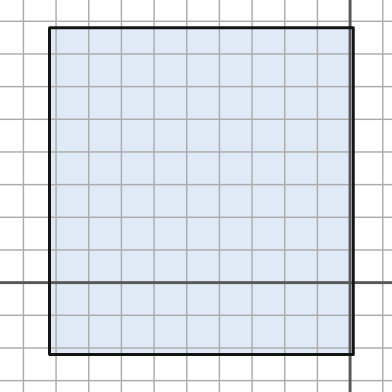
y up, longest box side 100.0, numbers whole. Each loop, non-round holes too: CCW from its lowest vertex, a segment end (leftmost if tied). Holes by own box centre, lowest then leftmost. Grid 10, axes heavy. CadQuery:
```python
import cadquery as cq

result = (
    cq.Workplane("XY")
    .moveTo(-92.0, -22.0)
    .lineTo(1.0, -22.0)
    .lineTo(1.0, 78.0)
    .lineTo(-92.0, 78.0)
    .close()
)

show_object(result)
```